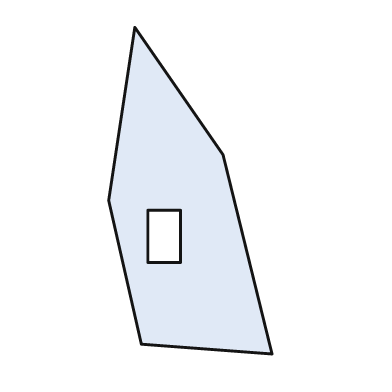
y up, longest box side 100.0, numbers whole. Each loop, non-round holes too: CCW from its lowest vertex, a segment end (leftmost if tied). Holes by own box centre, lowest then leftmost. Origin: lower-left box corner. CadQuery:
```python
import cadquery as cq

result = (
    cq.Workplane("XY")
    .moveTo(50.0, 0.0)
    .lineTo(35.0, 61.0)
    .lineTo(8.0, 100.0)
    .lineTo(0.0, 47.0)
    .lineTo(10.0, 3.0)
    .close()
    .moveTo(12.0, 28.0)
    .lineTo(22.0, 28.0)
    .lineTo(22.0, 44.0)
    .lineTo(12.0, 44.0)
    .close()
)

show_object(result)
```